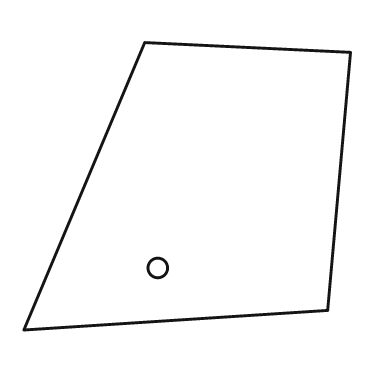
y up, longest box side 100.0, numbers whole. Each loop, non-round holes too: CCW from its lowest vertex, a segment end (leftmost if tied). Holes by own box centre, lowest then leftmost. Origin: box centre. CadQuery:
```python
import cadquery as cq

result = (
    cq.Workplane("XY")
    .moveTo(-50.0, -44.0)
    .lineTo(43.0, -38.0)
    .lineTo(50.0, 41.0)
    .lineTo(-13.0, 44.0)
    .close()
    .moveTo(-9.0, -25.0)
    .circle(3.0)
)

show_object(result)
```